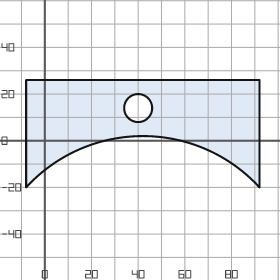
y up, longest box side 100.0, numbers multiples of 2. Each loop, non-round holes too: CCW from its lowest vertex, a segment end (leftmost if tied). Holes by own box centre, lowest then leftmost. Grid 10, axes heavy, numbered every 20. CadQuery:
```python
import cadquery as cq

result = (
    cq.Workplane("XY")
    .moveTo(-8.0, -20.0)
    .threePointArc((42.0, 2.0), (92.0, -20.0))
    .lineTo(92.0, 26.0)
    .lineTo(-8.0, 26.0)
    .close()
    .moveTo(40.0, 14.0)
    .circle(6.0)
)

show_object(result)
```